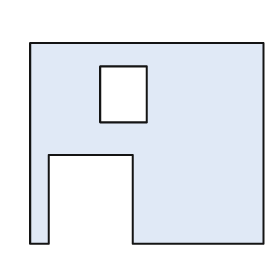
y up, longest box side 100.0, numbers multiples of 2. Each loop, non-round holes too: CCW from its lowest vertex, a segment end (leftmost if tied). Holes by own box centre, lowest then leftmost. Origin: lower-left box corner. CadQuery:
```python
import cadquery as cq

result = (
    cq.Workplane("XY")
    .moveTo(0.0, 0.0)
    .lineTo(8.0, 0.0)
    .lineTo(8.0, 38.0)
    .lineTo(44.0, 38.0)
    .lineTo(44.0, 0.0)
    .lineTo(100.0, 0.0)
    .lineTo(100.0, 86.0)
    .lineTo(0.0, 86.0)
    .close()
    .moveTo(30.0, 52.0)
    .lineTo(50.0, 52.0)
    .lineTo(50.0, 76.0)
    .lineTo(30.0, 76.0)
    .close()
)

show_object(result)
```